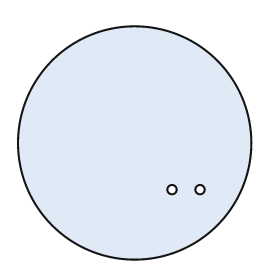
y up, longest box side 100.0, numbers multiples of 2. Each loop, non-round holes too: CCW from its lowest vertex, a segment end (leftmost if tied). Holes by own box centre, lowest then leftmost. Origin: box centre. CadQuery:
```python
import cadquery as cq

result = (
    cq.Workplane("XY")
    .moveTo(0.0, 0.0)
    .circle(50.0)
    .moveTo(16.0, -20.0)
    .circle(2.0)
    .moveTo(28.0, -20.0)
    .circle(2.0)
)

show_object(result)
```